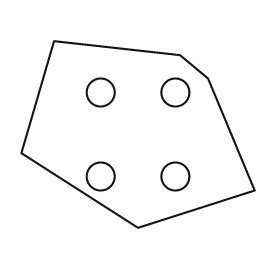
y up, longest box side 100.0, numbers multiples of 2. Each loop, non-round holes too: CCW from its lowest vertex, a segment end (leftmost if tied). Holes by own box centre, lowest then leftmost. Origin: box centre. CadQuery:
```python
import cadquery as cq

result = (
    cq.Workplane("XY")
    .moveTo(0.0, -40.0)
    .lineTo(50.0, -24.0)
    .lineTo(30.0, 24.0)
    .lineTo(18.0, 34.0)
    .lineTo(-36.0, 40.0)
    .lineTo(-50.0, -8.0)
    .close()
    .moveTo(-16.0, -18.0)
    .circle(6.0)
    .moveTo(16.0, -18.0)
    .circle(6.0)
    .moveTo(-16.0, 18.0)
    .circle(6.0)
    .moveTo(16.0, 18.0)
    .circle(6.0)
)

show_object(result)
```